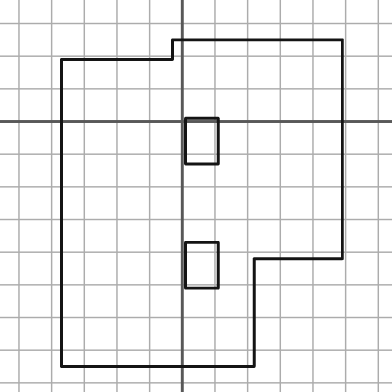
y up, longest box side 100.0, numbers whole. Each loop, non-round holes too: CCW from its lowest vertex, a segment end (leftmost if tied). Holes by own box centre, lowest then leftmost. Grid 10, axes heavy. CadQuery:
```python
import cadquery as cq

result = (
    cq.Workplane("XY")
    .moveTo(-37.0, -75.0)
    .lineTo(22.0, -75.0)
    .lineTo(22.0, -42.0)
    .lineTo(49.0, -42.0)
    .lineTo(49.0, 25.0)
    .lineTo(-3.0, 25.0)
    .lineTo(-3.0, 19.0)
    .lineTo(-37.0, 19.0)
    .close()
    .moveTo(1.0, -51.0)
    .lineTo(11.0, -51.0)
    .lineTo(11.0, -37.0)
    .lineTo(1.0, -37.0)
    .close()
    .moveTo(1.0, -13.0)
    .lineTo(11.0, -13.0)
    .lineTo(11.0, 1.0)
    .lineTo(1.0, 1.0)
    .close()
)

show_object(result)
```